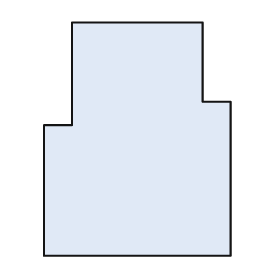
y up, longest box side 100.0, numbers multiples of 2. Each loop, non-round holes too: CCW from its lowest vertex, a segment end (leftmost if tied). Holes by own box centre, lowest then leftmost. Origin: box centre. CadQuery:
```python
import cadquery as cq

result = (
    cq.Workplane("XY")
    .moveTo(-40.0, -50.0)
    .lineTo(40.0, -50.0)
    .lineTo(40.0, 16.0)
    .lineTo(28.0, 16.0)
    .lineTo(28.0, 50.0)
    .lineTo(-28.0, 50.0)
    .lineTo(-28.0, 6.0)
    .lineTo(-40.0, 6.0)
    .close()
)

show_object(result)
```